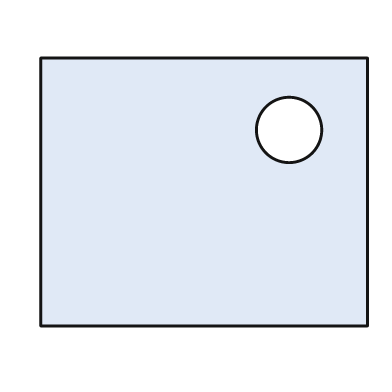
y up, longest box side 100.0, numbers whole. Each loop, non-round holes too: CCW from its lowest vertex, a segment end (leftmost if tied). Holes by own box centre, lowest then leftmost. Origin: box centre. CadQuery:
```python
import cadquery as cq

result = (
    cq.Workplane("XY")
    .moveTo(-50.0, -41.0)
    .lineTo(50.0, -41.0)
    .lineTo(50.0, 41.0)
    .lineTo(-50.0, 41.0)
    .close()
    .moveTo(26.0, 19.0)
    .circle(10.0)
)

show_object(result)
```